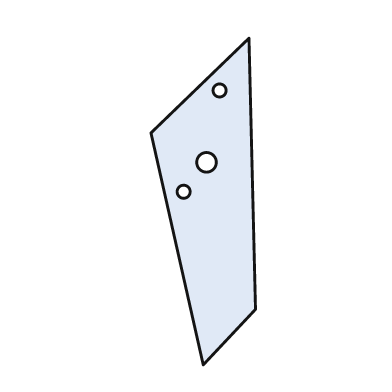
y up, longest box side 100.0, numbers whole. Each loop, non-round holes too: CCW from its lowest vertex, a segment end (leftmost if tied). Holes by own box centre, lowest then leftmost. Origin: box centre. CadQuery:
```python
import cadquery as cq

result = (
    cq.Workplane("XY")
    .moveTo(0.0, -50.0)
    .lineTo(16.0, -33.0)
    .lineTo(14.0, 50.0)
    .lineTo(-16.0, 21.0)
    .close()
    .moveTo(-6.0, 3.0)
    .circle(2.0)
    .moveTo(1.0, 12.0)
    .circle(3.0)
    .moveTo(5.0, 34.0)
    .circle(2.0)
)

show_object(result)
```